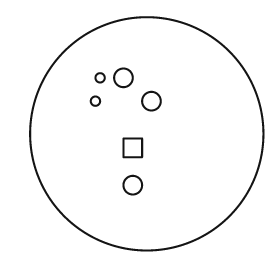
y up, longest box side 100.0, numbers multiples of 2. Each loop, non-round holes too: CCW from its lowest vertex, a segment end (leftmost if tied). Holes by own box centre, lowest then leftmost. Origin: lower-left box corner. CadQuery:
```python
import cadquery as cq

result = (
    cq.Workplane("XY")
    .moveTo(50.0, 50.0)
    .circle(50.0)
    .moveTo(44.0, 28.0)
    .circle(4.0)
    .moveTo(40.0, 40.0)
    .lineTo(48.0, 40.0)
    .lineTo(48.0, 48.0)
    .lineTo(40.0, 48.0)
    .close()
    .moveTo(28.0, 64.0)
    .circle(2.0)
    .moveTo(52.0, 64.0)
    .circle(4.0)
    .moveTo(30.0, 74.0)
    .circle(2.0)
    .moveTo(40.0, 74.0)
    .circle(4.0)
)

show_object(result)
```